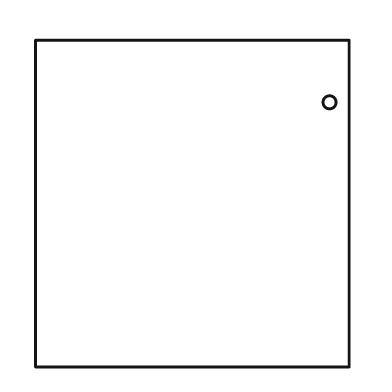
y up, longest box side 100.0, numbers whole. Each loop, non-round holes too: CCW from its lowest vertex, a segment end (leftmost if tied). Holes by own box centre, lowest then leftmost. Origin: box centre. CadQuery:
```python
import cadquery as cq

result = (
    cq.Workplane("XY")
    .moveTo(-48.0, -50.0)
    .lineTo(48.0, -50.0)
    .lineTo(48.0, 50.0)
    .lineTo(-48.0, 50.0)
    .close()
    .moveTo(42.0, 31.0)
    .circle(2.0)
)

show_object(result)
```